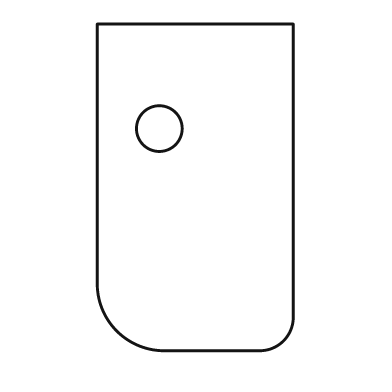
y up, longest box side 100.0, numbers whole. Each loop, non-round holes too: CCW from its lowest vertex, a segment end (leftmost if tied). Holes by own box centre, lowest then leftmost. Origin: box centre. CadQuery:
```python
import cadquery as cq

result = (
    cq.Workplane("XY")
    .moveTo(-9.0, -50.0)
    .lineTo(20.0, -50.0)
    .threePointArc((27.0, -47.0), (30.0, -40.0))
    .lineTo(30.0, 50.0)
    .lineTo(-30.0, 50.0)
    .lineTo(-30.0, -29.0)
    .threePointArc((-24.0, -44.0), (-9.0, -50.0))
    .close()
    .moveTo(-11.0, 18.0)
    .circle(7.0)
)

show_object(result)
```